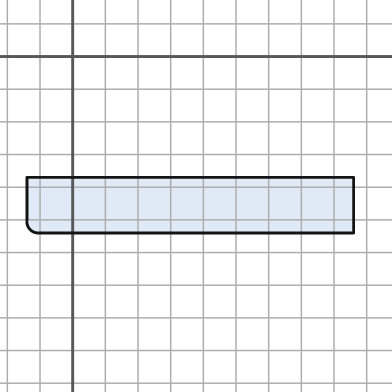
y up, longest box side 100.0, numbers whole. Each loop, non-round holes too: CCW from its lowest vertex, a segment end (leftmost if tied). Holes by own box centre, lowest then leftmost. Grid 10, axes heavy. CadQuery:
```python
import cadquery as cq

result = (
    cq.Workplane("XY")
    .moveTo(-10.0, -54.0)
    .lineTo(86.0, -54.0)
    .lineTo(86.0, -37.0)
    .lineTo(-14.0, -37.0)
    .lineTo(-14.0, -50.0)
    .threePointArc((-13.0, -53.0), (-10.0, -54.0))
    .close()
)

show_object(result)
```